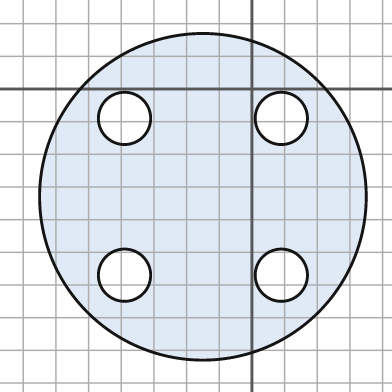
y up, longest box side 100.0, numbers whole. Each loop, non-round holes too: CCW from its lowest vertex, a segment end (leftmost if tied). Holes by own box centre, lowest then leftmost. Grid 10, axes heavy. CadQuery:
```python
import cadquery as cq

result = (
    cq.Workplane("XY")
    .moveTo(-15.0, -33.0)
    .circle(50.0)
    .moveTo(-39.0, -57.0)
    .circle(8.0)
    .moveTo(9.0, -57.0)
    .circle(8.0)
    .moveTo(-39.0, -9.0)
    .circle(8.0)
    .moveTo(9.0, -9.0)
    .circle(8.0)
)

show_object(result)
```